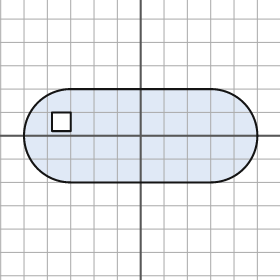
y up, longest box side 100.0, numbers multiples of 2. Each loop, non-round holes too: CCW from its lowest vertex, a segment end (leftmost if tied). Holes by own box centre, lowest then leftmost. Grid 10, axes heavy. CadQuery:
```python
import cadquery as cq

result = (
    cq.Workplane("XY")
    .moveTo(-30.0, -20.0)
    .lineTo(30.0, -20.0)
    .threePointArc((50.0, 0.0), (30.0, 20.0))
    .lineTo(-30.0, 20.0)
    .threePointArc((-50.0, 0.0), (-30.0, -20.0))
    .close()
    .moveTo(-38.0, 2.0)
    .lineTo(-30.0, 2.0)
    .lineTo(-30.0, 10.0)
    .lineTo(-38.0, 10.0)
    .close()
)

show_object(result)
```